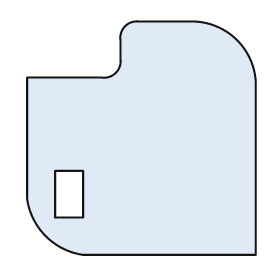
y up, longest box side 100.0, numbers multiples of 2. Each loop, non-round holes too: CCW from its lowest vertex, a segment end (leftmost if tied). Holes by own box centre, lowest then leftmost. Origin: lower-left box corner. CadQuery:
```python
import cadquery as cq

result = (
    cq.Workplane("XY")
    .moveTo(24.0, 0.0)
    .lineTo(98.0, 0.0)
    .lineTo(98.0, 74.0)
    .threePointArc((90.0, 92.0), (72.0, 100.0))
    .lineTo(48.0, 100.0)
    .threePointArc((42.0, 98.0), (40.0, 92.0))
    .lineTo(40.0, 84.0)
    .threePointArc((38.0, 78.0), (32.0, 76.0))
    .lineTo(0.0, 76.0)
    .lineTo(0.0, 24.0)
    .threePointArc((8.0, 8.0), (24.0, 0.0))
    .close()
    .moveTo(12.0, 16.0)
    .lineTo(24.0, 16.0)
    .lineTo(24.0, 36.0)
    .lineTo(12.0, 36.0)
    .close()
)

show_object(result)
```